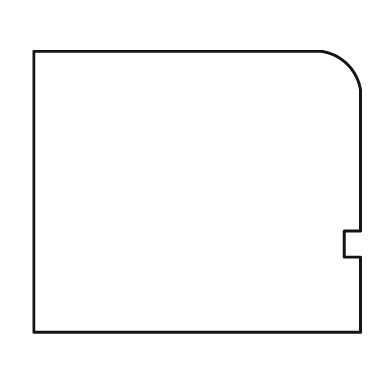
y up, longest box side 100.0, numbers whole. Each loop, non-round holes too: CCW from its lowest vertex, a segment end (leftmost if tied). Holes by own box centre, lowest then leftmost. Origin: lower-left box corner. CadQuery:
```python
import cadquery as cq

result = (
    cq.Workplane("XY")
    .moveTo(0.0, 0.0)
    .lineTo(100.0, 0.0)
    .lineTo(100.0, 23.0)
    .lineTo(95.0, 23.0)
    .lineTo(95.0, 31.0)
    .lineTo(100.0, 31.0)
    .lineTo(100.0, 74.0)
    .threePointArc((96.0, 82.0), (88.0, 86.0))
    .lineTo(0.0, 86.0)
    .close()
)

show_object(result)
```